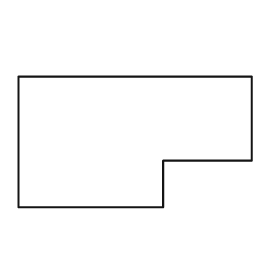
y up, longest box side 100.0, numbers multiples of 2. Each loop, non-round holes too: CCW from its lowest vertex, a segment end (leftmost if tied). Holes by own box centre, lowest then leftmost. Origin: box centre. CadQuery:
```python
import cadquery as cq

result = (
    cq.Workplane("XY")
    .moveTo(-50.0, -28.0)
    .lineTo(12.0, -28.0)
    .lineTo(12.0, -8.0)
    .lineTo(50.0, -8.0)
    .lineTo(50.0, 28.0)
    .lineTo(-50.0, 28.0)
    .close()
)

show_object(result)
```